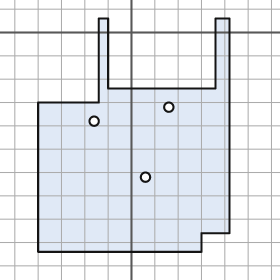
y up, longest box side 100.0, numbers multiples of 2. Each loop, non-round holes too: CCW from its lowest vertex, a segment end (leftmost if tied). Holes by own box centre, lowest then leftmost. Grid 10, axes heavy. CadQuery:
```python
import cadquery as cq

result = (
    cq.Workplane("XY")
    .moveTo(-40.0, -94.0)
    .lineTo(30.0, -94.0)
    .lineTo(30.0, -86.0)
    .lineTo(42.0, -86.0)
    .lineTo(42.0, 6.0)
    .lineTo(36.0, 6.0)
    .lineTo(36.0, -24.0)
    .lineTo(-10.0, -24.0)
    .lineTo(-10.0, 6.0)
    .lineTo(-14.0, 6.0)
    .lineTo(-14.0, -30.0)
    .lineTo(-40.0, -30.0)
    .close()
    .moveTo(6.0, -62.0)
    .circle(2.0)
    .moveTo(-16.0, -38.0)
    .circle(2.0)
    .moveTo(16.0, -32.0)
    .circle(2.0)
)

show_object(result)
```